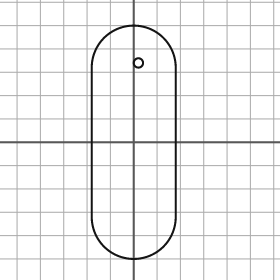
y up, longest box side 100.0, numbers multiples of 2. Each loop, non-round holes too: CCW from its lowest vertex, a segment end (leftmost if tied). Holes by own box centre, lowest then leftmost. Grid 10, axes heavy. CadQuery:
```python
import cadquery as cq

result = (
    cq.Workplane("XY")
    .moveTo(-18.0, -32.0)
    .threePointArc((0.0, -50.0), (18.0, -32.0))
    .lineTo(18.0, 32.0)
    .threePointArc((0.0, 50.0), (-18.0, 32.0))
    .close()
    .moveTo(2.0, 34.0)
    .circle(2.0)
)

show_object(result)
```